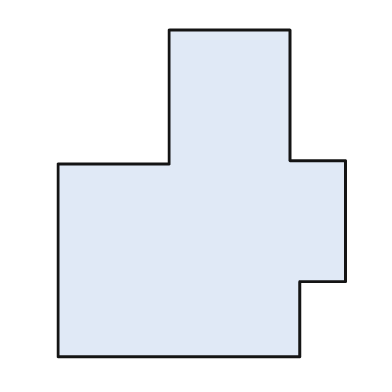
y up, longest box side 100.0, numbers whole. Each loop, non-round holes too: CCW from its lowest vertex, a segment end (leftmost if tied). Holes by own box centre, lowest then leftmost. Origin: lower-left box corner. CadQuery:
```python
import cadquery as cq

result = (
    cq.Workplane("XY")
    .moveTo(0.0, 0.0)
    .lineTo(74.0, 0.0)
    .lineTo(74.0, 23.0)
    .lineTo(88.0, 23.0)
    .lineTo(88.0, 60.0)
    .lineTo(71.0, 60.0)
    .lineTo(71.0, 100.0)
    .lineTo(34.0, 100.0)
    .lineTo(34.0, 59.0)
    .lineTo(0.0, 59.0)
    .close()
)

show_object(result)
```